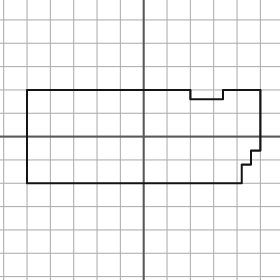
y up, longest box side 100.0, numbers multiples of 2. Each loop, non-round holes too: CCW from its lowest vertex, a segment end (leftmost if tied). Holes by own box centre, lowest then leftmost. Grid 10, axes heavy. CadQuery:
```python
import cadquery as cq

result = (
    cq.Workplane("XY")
    .moveTo(-50.0, -20.0)
    .lineTo(42.0, -20.0)
    .lineTo(42.0, -12.0)
    .lineTo(46.0, -12.0)
    .lineTo(46.0, -6.0)
    .lineTo(50.0, -6.0)
    .lineTo(50.0, 20.0)
    .lineTo(34.0, 20.0)
    .lineTo(34.0, 16.0)
    .lineTo(20.0, 16.0)
    .lineTo(20.0, 20.0)
    .lineTo(-50.0, 20.0)
    .close()
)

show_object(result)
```